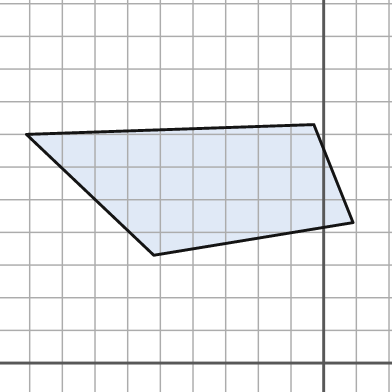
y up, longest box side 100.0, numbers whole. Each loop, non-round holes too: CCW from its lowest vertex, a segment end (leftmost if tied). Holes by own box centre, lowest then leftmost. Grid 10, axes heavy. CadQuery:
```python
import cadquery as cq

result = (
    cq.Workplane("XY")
    .moveTo(-52.0, 33.0)
    .lineTo(9.0, 43.0)
    .lineTo(-3.0, 73.0)
    .lineTo(-91.0, 70.0)
    .close()
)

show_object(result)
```